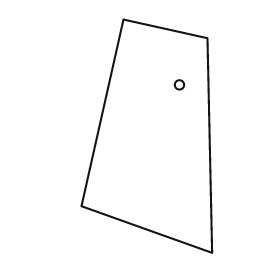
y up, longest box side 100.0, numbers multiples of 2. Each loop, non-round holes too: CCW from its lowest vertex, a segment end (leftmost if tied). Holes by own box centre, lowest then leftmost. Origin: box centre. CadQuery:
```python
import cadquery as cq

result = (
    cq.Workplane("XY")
    .moveTo(28.0, -50.0)
    .lineTo(26.0, 42.0)
    .lineTo(-10.0, 50.0)
    .lineTo(-28.0, -30.0)
    .close()
    .moveTo(14.0, 22.0)
    .circle(2.0)
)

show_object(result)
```